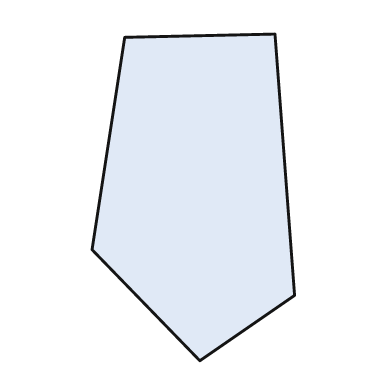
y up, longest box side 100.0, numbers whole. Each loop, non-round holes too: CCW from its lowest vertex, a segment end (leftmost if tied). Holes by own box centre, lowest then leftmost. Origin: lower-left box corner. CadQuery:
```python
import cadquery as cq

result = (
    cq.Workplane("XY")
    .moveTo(33.0, 0.0)
    .lineTo(62.0, 20.0)
    .lineTo(56.0, 100.0)
    .lineTo(10.0, 99.0)
    .lineTo(0.0, 34.0)
    .close()
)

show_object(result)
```